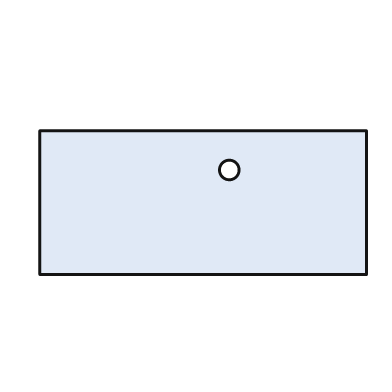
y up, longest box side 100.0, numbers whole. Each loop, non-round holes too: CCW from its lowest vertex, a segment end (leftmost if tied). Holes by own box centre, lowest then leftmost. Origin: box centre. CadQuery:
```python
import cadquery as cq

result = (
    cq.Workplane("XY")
    .moveTo(-50.0, -22.0)
    .lineTo(50.0, -22.0)
    .lineTo(50.0, 22.0)
    .lineTo(-50.0, 22.0)
    .close()
    .moveTo(8.0, 10.0)
    .circle(3.0)
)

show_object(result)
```